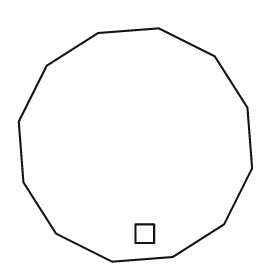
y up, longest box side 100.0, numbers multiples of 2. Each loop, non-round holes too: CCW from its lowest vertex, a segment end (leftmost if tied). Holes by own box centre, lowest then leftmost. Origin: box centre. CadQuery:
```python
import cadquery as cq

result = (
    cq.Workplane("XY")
    .moveTo(-10.0, -50.0)
    .lineTo(16.0, -48.0)
    .lineTo(38.0, -34.0)
    .lineTo(50.0, -10.0)
    .lineTo(48.0, 16.0)
    .lineTo(34.0, 38.0)
    .lineTo(10.0, 50.0)
    .lineTo(-16.0, 48.0)
    .lineTo(-38.0, 34.0)
    .lineTo(-50.0, 10.0)
    .lineTo(-48.0, -16.0)
    .lineTo(-34.0, -38.0)
    .close()
    .moveTo(0.0, -42.0)
    .lineTo(8.0, -42.0)
    .lineTo(8.0, -34.0)
    .lineTo(0.0, -34.0)
    .close()
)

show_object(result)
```